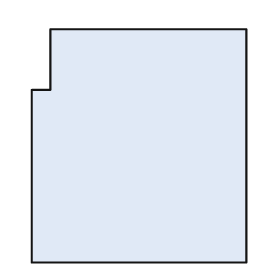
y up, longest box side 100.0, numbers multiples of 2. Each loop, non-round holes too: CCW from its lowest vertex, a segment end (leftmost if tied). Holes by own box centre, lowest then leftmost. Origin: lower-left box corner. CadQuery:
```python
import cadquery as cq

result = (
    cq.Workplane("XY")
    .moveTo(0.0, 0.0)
    .lineTo(92.0, 0.0)
    .lineTo(92.0, 100.0)
    .lineTo(8.0, 100.0)
    .lineTo(8.0, 74.0)
    .lineTo(0.0, 74.0)
    .close()
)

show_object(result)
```